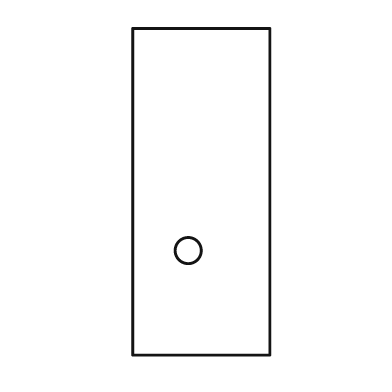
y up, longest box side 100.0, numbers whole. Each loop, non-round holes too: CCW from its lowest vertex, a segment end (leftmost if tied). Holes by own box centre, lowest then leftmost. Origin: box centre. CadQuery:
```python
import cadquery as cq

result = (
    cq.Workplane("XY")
    .moveTo(-21.0, -50.0)
    .lineTo(21.0, -50.0)
    .lineTo(21.0, 50.0)
    .lineTo(-21.0, 50.0)
    .close()
    .moveTo(-4.0, -18.0)
    .circle(4.0)
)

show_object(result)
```